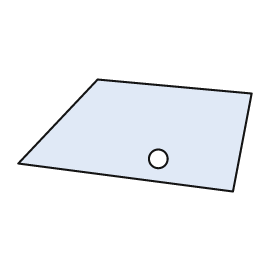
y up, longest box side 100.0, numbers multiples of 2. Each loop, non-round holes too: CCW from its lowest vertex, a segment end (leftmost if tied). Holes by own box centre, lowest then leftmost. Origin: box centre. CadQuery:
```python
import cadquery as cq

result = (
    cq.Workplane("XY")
    .moveTo(42.0, -24.0)
    .lineTo(50.0, 18.0)
    .lineTo(-16.0, 24.0)
    .lineTo(-50.0, -12.0)
    .close()
    .moveTo(10.0, -10.0)
    .circle(4.0)
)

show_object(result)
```